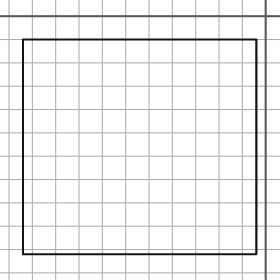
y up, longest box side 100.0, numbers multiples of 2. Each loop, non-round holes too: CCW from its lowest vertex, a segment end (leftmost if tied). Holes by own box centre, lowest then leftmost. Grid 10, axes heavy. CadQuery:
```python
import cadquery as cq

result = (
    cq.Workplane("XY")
    .moveTo(-104.0, -102.0)
    .lineTo(-4.0, -102.0)
    .lineTo(-4.0, -10.0)
    .lineTo(-104.0, -10.0)
    .close()
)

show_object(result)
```